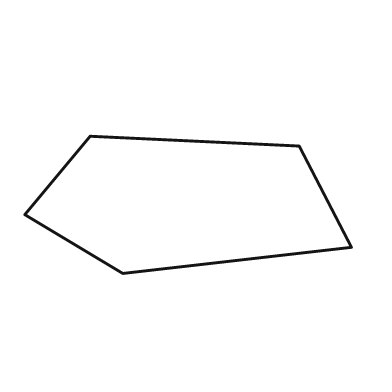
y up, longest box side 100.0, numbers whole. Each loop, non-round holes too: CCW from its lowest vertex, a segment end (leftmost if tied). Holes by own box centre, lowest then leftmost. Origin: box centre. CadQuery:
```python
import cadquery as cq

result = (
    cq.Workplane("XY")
    .moveTo(-20.0, -21.0)
    .lineTo(50.0, -13.0)
    .lineTo(34.0, 18.0)
    .lineTo(-30.0, 21.0)
    .lineTo(-50.0, -3.0)
    .close()
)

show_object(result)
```